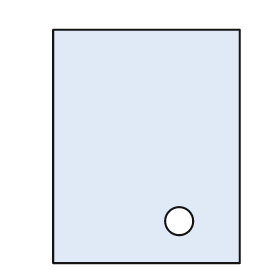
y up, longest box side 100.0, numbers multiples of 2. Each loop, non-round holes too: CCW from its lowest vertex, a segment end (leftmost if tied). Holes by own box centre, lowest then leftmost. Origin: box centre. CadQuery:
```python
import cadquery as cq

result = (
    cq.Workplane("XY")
    .moveTo(-40.0, -50.0)
    .lineTo(40.0, -50.0)
    .lineTo(40.0, 50.0)
    .lineTo(-40.0, 50.0)
    .close()
    .moveTo(14.0, -32.0)
    .circle(6.0)
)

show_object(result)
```